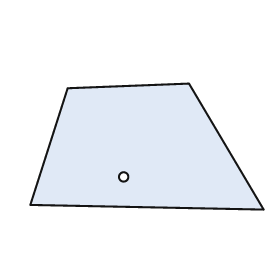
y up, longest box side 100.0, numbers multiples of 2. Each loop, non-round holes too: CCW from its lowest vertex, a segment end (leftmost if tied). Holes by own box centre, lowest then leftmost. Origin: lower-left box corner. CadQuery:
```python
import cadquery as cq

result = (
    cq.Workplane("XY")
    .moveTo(100.0, 0.0)
    .lineTo(68.0, 54.0)
    .lineTo(16.0, 52.0)
    .lineTo(0.0, 2.0)
    .close()
    .moveTo(40.0, 14.0)
    .circle(2.0)
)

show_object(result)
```